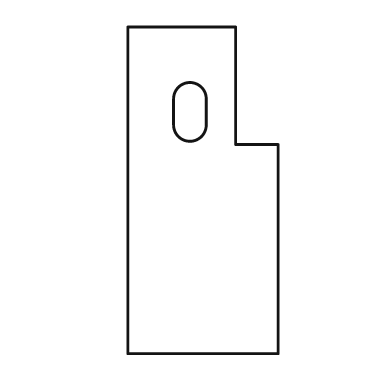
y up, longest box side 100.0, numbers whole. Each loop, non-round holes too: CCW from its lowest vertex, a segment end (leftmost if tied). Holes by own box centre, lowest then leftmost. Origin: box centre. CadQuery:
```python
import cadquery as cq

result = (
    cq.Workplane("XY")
    .moveTo(-23.0, -50.0)
    .lineTo(23.0, -50.0)
    .lineTo(23.0, 14.0)
    .lineTo(10.0, 14.0)
    .lineTo(10.0, 50.0)
    .lineTo(-23.0, 50.0)
    .close()
    .moveTo(-9.0, 20.0)
    .threePointArc((-4.0, 15.0), (1.0, 20.0))
    .lineTo(1.0, 28.0)
    .threePointArc((-4.0, 33.0), (-9.0, 28.0))
    .close()
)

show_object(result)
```